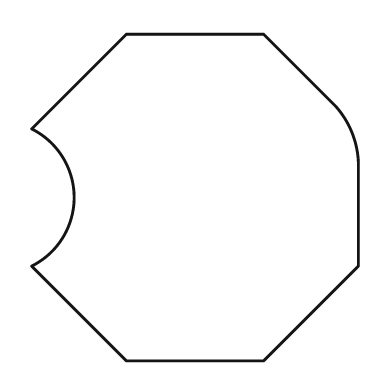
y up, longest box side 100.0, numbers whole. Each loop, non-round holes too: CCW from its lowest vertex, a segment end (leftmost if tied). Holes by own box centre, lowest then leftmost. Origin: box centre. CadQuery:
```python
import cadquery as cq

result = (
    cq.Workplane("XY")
    .moveTo(-21.0, -50.0)
    .lineTo(21.0, -50.0)
    .lineTo(50.0, -21.0)
    .lineTo(50.0, 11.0)
    .threePointArc((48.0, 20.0), (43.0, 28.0))
    .lineTo(21.0, 50.0)
    .lineTo(-21.0, 50.0)
    .lineTo(-50.0, 21.0)
    .threePointArc((-37.0, 0.0), (-50.0, -21.0))
    .close()
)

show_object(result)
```